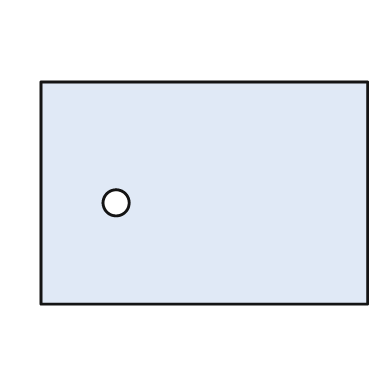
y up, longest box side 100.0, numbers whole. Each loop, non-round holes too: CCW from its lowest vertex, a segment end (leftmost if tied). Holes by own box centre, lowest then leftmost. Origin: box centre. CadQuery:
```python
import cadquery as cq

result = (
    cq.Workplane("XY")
    .moveTo(-50.0, -34.0)
    .lineTo(50.0, -34.0)
    .lineTo(50.0, 34.0)
    .lineTo(-50.0, 34.0)
    .close()
    .moveTo(-27.0, -3.0)
    .circle(4.0)
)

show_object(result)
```